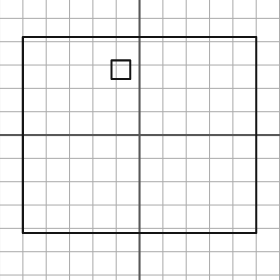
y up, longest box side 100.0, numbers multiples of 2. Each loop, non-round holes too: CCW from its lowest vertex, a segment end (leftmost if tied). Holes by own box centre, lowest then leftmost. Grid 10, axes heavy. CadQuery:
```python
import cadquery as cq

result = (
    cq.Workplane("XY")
    .moveTo(-50.0, -42.0)
    .lineTo(50.0, -42.0)
    .lineTo(50.0, 42.0)
    .lineTo(-50.0, 42.0)
    .close()
    .moveTo(-12.0, 24.0)
    .lineTo(-4.0, 24.0)
    .lineTo(-4.0, 32.0)
    .lineTo(-12.0, 32.0)
    .close()
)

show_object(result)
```